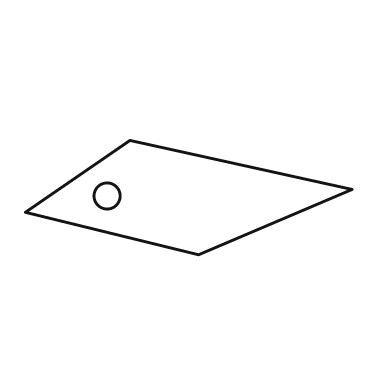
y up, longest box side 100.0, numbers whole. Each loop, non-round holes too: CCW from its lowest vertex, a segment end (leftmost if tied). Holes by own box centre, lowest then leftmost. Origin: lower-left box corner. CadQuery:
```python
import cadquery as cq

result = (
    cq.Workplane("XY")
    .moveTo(53.0, 0.0)
    .lineTo(100.0, 20.0)
    .lineTo(32.0, 35.0)
    .lineTo(0.0, 13.0)
    .close()
    .moveTo(25.0, 18.0)
    .circle(4.0)
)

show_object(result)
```